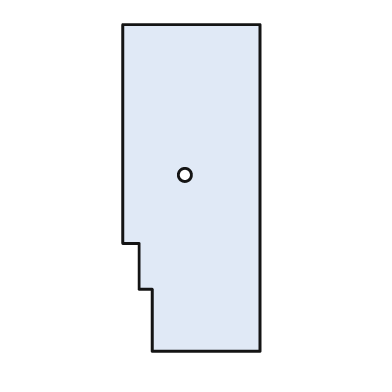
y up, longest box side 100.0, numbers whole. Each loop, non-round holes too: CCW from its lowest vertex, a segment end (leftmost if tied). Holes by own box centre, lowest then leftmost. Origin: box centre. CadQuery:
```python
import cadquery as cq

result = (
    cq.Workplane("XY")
    .moveTo(-12.0, -50.0)
    .lineTo(21.0, -50.0)
    .lineTo(21.0, 50.0)
    .lineTo(-21.0, 50.0)
    .lineTo(-21.0, -17.0)
    .lineTo(-16.0, -17.0)
    .lineTo(-16.0, -31.0)
    .lineTo(-12.0, -31.0)
    .close()
    .moveTo(-2.0, 4.0)
    .circle(2.0)
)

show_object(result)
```